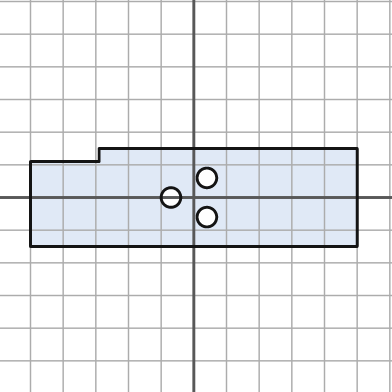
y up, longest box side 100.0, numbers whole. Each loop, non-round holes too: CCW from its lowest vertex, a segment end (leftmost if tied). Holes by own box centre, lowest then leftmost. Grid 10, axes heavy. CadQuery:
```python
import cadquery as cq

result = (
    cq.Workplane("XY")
    .moveTo(-50.0, -15.0)
    .lineTo(50.0, -15.0)
    .lineTo(50.0, 15.0)
    .lineTo(-29.0, 15.0)
    .lineTo(-29.0, 11.0)
    .lineTo(-50.0, 11.0)
    .close()
    .moveTo(4.0, -6.0)
    .circle(3.0)
    .moveTo(-7.0, 0.0)
    .circle(3.0)
    .moveTo(4.0, 6.0)
    .circle(3.0)
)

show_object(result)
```